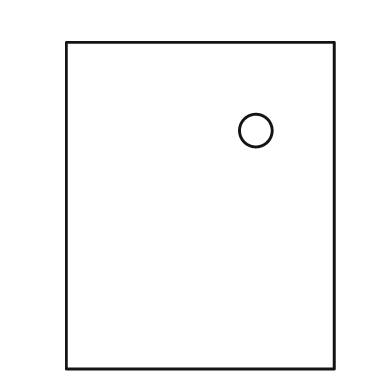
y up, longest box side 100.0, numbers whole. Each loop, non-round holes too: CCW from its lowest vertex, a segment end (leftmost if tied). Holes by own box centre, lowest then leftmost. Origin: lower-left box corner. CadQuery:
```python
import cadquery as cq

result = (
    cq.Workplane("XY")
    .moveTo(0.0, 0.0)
    .lineTo(82.0, 0.0)
    .lineTo(82.0, 100.0)
    .lineTo(0.0, 100.0)
    .close()
    .moveTo(58.0, 73.0)
    .circle(5.0)
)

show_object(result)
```